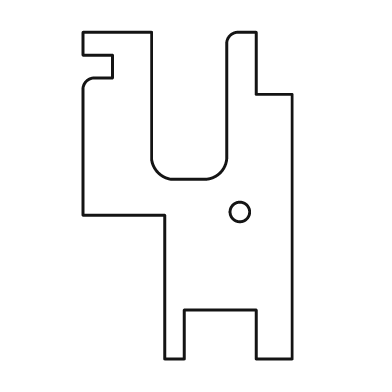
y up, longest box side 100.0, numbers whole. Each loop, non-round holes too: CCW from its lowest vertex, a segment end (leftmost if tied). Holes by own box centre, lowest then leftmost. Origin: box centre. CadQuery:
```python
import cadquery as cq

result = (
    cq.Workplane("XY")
    .moveTo(-7.0, -50.0)
    .lineTo(-1.0, -50.0)
    .lineTo(-1.0, -35.0)
    .lineTo(21.0, -35.0)
    .lineTo(21.0, -50.0)
    .lineTo(32.0, -50.0)
    .lineTo(32.0, 31.0)
    .lineTo(21.0, 31.0)
    .lineTo(21.0, 50.0)
    .lineTo(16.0, 50.0)
    .threePointArc((13.0, 49.0), (12.0, 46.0))
    .lineTo(12.0, 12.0)
    .threePointArc((10.0, 7.0), (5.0, 5.0))
    .lineTo(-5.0, 5.0)
    .threePointArc((-9.0, 7.0), (-11.0, 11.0))
    .lineTo(-11.0, 50.0)
    .lineTo(-32.0, 50.0)
    .lineTo(-32.0, 43.0)
    .lineTo(-23.0, 43.0)
    .lineTo(-23.0, 36.0)
    .lineTo(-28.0, 36.0)
    .threePointArc((-31.0, 35.0), (-32.0, 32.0))
    .lineTo(-32.0, -6.0)
    .lineTo(-7.0, -6.0)
    .close()
    .moveTo(16.0, -5.0)
    .circle(3.0)
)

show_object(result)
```